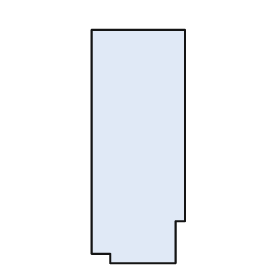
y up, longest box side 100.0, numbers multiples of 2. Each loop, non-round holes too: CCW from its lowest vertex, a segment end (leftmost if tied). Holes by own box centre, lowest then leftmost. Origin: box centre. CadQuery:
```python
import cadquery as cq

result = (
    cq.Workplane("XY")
    .moveTo(-12.0, -50.0)
    .lineTo(16.0, -50.0)
    .lineTo(16.0, -32.0)
    .lineTo(20.0, -32.0)
    .lineTo(20.0, 50.0)
    .lineTo(-20.0, 50.0)
    .lineTo(-20.0, -46.0)
    .lineTo(-12.0, -46.0)
    .close()
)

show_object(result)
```